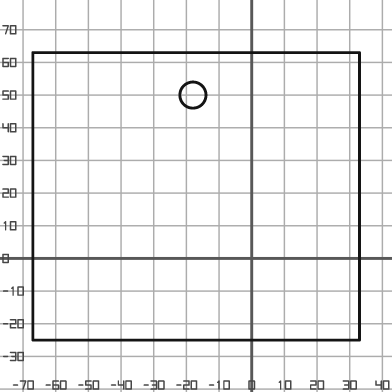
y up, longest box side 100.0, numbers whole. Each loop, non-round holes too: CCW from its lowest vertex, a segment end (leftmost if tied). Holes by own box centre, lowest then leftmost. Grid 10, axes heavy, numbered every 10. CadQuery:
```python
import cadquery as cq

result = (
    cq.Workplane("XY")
    .moveTo(-67.0, -25.0)
    .lineTo(33.0, -25.0)
    .lineTo(33.0, 63.0)
    .lineTo(-67.0, 63.0)
    .close()
    .moveTo(-18.0, 50.0)
    .circle(4.0)
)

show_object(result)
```